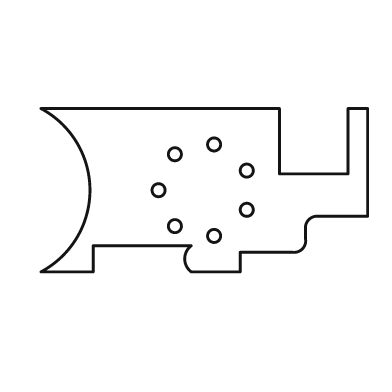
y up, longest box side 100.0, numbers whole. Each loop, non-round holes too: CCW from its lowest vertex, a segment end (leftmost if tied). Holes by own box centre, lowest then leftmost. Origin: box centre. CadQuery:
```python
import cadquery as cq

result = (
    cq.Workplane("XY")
    .moveTo(-50.0, -25.0)
    .lineTo(-34.0, -25.0)
    .lineTo(-34.0, -17.0)
    .lineTo(-4.0, -17.0)
    .threePointArc((-6.0, -21.0), (-4.0, -25.0))
    .lineTo(11.0, -25.0)
    .lineTo(11.0, -19.0)
    .lineTo(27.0, -19.0)
    .threePointArc((30.0, -18.0), (31.0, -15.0))
    .lineTo(31.0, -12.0)
    .threePointArc((32.0, -9.0), (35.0, -8.0))
    .lineTo(50.0, -8.0)
    .lineTo(50.0, 25.0)
    .lineTo(44.0, 25.0)
    .lineTo(44.0, 5.0)
    .lineTo(23.0, 5.0)
    .lineTo(23.0, 25.0)
    .lineTo(-50.0, 25.0)
    .threePointArc((-35.0, 0.0), (-50.0, -25.0))
    .close()
    .moveTo(3.0, -14.0)
    .circle(2.0)
    .moveTo(-9.0, -11.0)
    .circle(2.0)
    .moveTo(13.0, -6.0)
    .circle(2.0)
    .moveTo(-14.0, 0.0)
    .circle(2.0)
    .moveTo(13.0, 6.0)
    .circle(2.0)
    .moveTo(-9.0, 11.0)
    .circle(2.0)
    .moveTo(3.0, 14.0)
    .circle(2.0)
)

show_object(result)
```